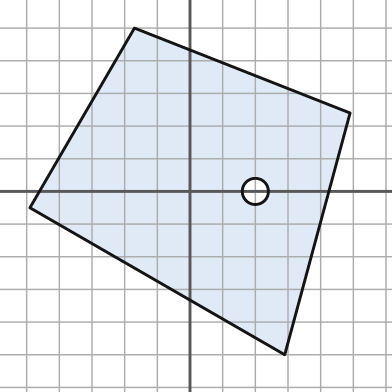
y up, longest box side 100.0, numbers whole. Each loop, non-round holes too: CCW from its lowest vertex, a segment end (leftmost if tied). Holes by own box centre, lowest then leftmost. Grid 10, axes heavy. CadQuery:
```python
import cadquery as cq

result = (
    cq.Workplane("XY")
    .moveTo(29.0, -50.0)
    .lineTo(49.0, 24.0)
    .lineTo(-17.0, 50.0)
    .lineTo(-49.0, -5.0)
    .close()
    .moveTo(20.0, 0.0)
    .circle(4.0)
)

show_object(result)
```